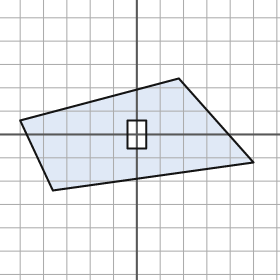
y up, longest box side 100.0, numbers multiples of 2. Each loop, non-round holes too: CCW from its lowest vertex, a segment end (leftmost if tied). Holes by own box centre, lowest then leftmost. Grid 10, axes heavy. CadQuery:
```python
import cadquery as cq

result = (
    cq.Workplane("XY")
    .moveTo(-36.0, -24.0)
    .lineTo(50.0, -12.0)
    .lineTo(18.0, 24.0)
    .lineTo(-50.0, 6.0)
    .close()
    .moveTo(-4.0, -6.0)
    .lineTo(4.0, -6.0)
    .lineTo(4.0, 6.0)
    .lineTo(-4.0, 6.0)
    .close()
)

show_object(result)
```